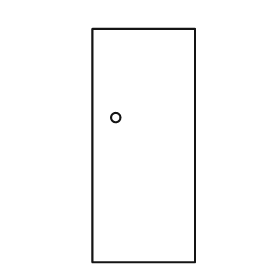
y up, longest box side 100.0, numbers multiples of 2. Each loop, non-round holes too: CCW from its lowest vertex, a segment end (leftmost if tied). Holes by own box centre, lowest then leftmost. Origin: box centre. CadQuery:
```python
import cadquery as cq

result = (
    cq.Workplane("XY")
    .moveTo(-22.0, -50.0)
    .lineTo(22.0, -50.0)
    .lineTo(22.0, 50.0)
    .lineTo(-22.0, 50.0)
    .close()
    .moveTo(-12.0, 12.0)
    .circle(2.0)
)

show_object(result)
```